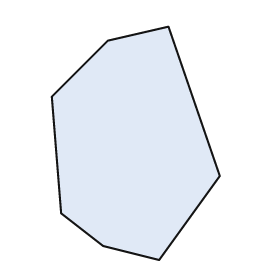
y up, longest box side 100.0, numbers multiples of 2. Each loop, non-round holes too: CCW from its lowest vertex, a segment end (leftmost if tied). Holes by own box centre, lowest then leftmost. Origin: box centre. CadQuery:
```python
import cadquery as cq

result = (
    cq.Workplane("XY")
    .moveTo(10.0, -50.0)
    .lineTo(36.0, -14.0)
    .lineTo(14.0, 50.0)
    .lineTo(-12.0, 44.0)
    .lineTo(-36.0, 20.0)
    .lineTo(-32.0, -30.0)
    .lineTo(-14.0, -44.0)
    .close()
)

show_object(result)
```